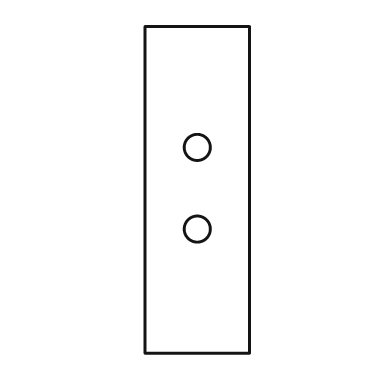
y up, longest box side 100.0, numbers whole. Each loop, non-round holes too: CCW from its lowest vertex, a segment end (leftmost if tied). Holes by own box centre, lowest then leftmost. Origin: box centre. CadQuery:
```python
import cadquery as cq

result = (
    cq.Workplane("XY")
    .moveTo(-16.0, -50.0)
    .lineTo(16.0, -50.0)
    .lineTo(16.0, 50.0)
    .lineTo(-16.0, 50.0)
    .close()
    .moveTo(0.0, -12.0)
    .circle(4.0)
    .moveTo(0.0, 13.0)
    .circle(4.0)
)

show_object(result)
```